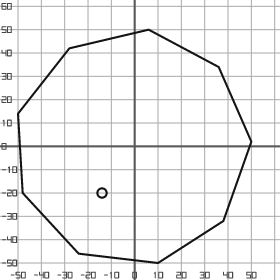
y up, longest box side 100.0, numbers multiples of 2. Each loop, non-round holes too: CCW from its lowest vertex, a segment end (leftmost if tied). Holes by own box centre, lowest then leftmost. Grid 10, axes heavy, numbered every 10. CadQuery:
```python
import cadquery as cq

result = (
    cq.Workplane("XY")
    .moveTo(10.0, -50.0)
    .lineTo(38.0, -32.0)
    .lineTo(50.0, 2.0)
    .lineTo(36.0, 34.0)
    .lineTo(6.0, 50.0)
    .lineTo(-28.0, 42.0)
    .lineTo(-50.0, 14.0)
    .lineTo(-48.0, -20.0)
    .lineTo(-24.0, -46.0)
    .close()
    .moveTo(-14.0, -20.0)
    .circle(2.0)
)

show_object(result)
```